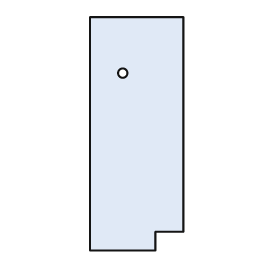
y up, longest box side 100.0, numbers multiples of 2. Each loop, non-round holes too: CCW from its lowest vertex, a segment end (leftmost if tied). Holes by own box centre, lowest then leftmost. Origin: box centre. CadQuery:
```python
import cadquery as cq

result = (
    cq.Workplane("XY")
    .moveTo(-20.0, -50.0)
    .lineTo(8.0, -50.0)
    .lineTo(8.0, -42.0)
    .lineTo(20.0, -42.0)
    .lineTo(20.0, 50.0)
    .lineTo(-20.0, 50.0)
    .close()
    .moveTo(-6.0, 26.0)
    .circle(2.0)
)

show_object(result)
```